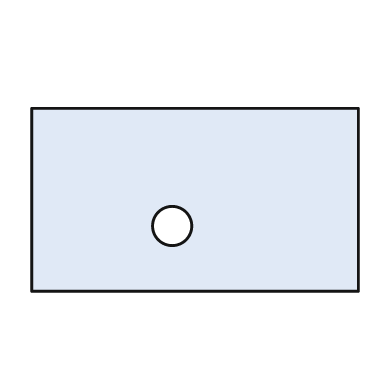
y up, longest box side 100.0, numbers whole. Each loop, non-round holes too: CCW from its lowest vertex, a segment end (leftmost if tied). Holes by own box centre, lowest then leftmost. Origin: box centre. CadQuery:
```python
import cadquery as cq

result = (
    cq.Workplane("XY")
    .moveTo(-50.0, -28.0)
    .lineTo(50.0, -28.0)
    .lineTo(50.0, 28.0)
    .lineTo(-50.0, 28.0)
    .close()
    .moveTo(-7.0, -8.0)
    .circle(6.0)
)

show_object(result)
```